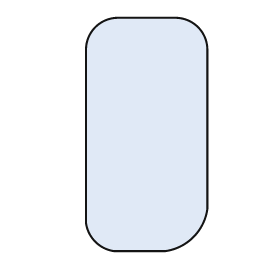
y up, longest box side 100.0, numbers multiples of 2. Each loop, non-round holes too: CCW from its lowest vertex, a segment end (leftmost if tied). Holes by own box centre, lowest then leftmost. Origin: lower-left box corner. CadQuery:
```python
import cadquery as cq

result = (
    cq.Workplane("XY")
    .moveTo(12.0, 0.0)
    .lineTo(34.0, 0.0)
    .threePointArc((46.0, 6.0), (52.0, 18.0))
    .lineTo(52.0, 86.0)
    .threePointArc((48.0, 96.0), (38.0, 100.0))
    .lineTo(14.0, 100.0)
    .threePointArc((4.0, 96.0), (0.0, 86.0))
    .lineTo(0.0, 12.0)
    .threePointArc((4.0, 4.0), (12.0, 0.0))
    .close()
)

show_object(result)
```